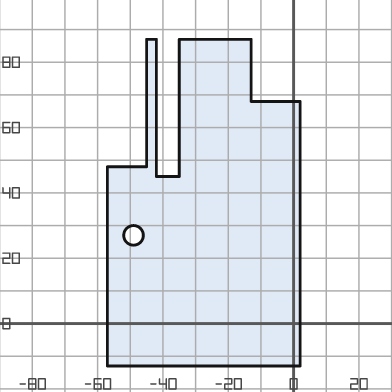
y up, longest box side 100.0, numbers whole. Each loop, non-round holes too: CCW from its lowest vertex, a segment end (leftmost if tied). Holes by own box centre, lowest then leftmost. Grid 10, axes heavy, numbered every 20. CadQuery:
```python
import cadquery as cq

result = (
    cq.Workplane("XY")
    .moveTo(-57.0, -13.0)
    .lineTo(2.0, -13.0)
    .lineTo(2.0, 68.0)
    .lineTo(-13.0, 68.0)
    .lineTo(-13.0, 87.0)
    .lineTo(-35.0, 87.0)
    .lineTo(-35.0, 45.0)
    .lineTo(-42.0, 45.0)
    .lineTo(-42.0, 87.0)
    .lineTo(-45.0, 87.0)
    .lineTo(-45.0, 48.0)
    .lineTo(-57.0, 48.0)
    .close()
    .moveTo(-49.0, 27.0)
    .circle(3.0)
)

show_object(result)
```